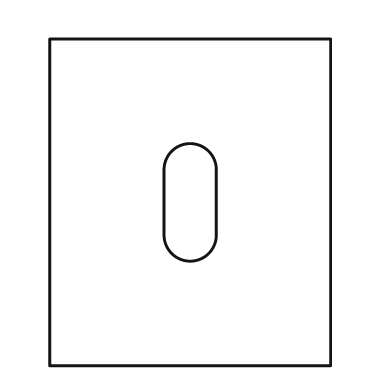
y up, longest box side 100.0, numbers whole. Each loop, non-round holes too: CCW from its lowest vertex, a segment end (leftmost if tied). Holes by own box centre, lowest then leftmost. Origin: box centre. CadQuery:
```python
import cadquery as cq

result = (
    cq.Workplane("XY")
    .moveTo(-43.0, -50.0)
    .lineTo(43.0, -50.0)
    .lineTo(43.0, 50.0)
    .lineTo(-43.0, 50.0)
    .close()
    .moveTo(-8.0, -10.0)
    .threePointArc((0.0, -18.0), (8.0, -10.0))
    .lineTo(8.0, 10.0)
    .threePointArc((0.0, 18.0), (-8.0, 10.0))
    .close()
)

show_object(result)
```